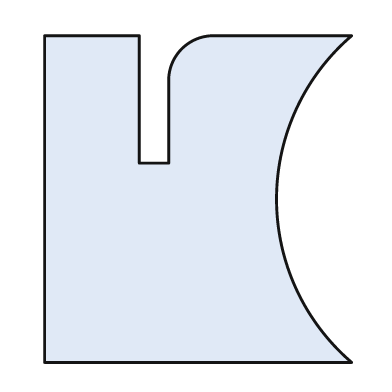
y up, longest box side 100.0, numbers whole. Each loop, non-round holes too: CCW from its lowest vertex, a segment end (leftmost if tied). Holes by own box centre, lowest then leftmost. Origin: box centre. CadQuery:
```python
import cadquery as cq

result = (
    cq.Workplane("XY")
    .moveTo(-47.0, -50.0)
    .lineTo(47.0, -50.0)
    .threePointArc((24.0, 0.0), (47.0, 50.0))
    .lineTo(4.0, 50.0)
    .threePointArc((-5.0, 46.0), (-9.0, 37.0))
    .lineTo(-9.0, 11.0)
    .lineTo(-18.0, 11.0)
    .lineTo(-18.0, 50.0)
    .lineTo(-47.0, 50.0)
    .close()
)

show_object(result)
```